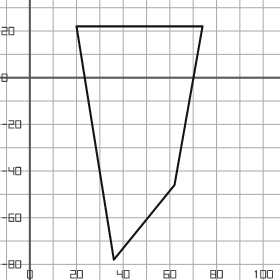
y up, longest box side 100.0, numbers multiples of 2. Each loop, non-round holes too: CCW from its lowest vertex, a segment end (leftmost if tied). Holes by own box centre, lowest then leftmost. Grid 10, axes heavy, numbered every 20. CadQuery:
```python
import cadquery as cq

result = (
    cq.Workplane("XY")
    .moveTo(36.0, -78.0)
    .lineTo(62.0, -46.0)
    .lineTo(74.0, 22.0)
    .lineTo(20.0, 22.0)
    .close()
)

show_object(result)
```